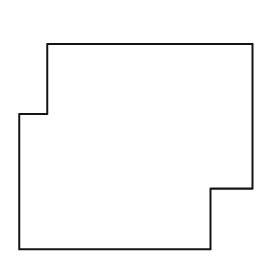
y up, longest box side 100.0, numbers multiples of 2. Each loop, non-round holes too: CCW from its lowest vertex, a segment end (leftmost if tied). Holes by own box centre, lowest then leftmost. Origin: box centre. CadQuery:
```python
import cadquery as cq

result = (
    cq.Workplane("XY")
    .moveTo(-50.0, -44.0)
    .lineTo(32.0, -44.0)
    .lineTo(32.0, -18.0)
    .lineTo(50.0, -18.0)
    .lineTo(50.0, 44.0)
    .lineTo(-38.0, 44.0)
    .lineTo(-38.0, 14.0)
    .lineTo(-50.0, 14.0)
    .close()
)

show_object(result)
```